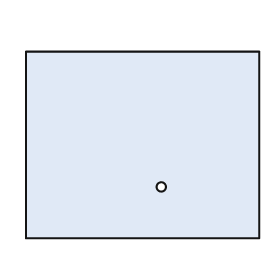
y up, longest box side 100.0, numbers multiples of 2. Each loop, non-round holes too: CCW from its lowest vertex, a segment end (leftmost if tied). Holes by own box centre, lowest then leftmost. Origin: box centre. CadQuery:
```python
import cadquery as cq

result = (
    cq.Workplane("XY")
    .moveTo(-50.0, -40.0)
    .lineTo(50.0, -40.0)
    .lineTo(50.0, 40.0)
    .lineTo(-50.0, 40.0)
    .close()
    .moveTo(8.0, -18.0)
    .circle(2.0)
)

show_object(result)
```